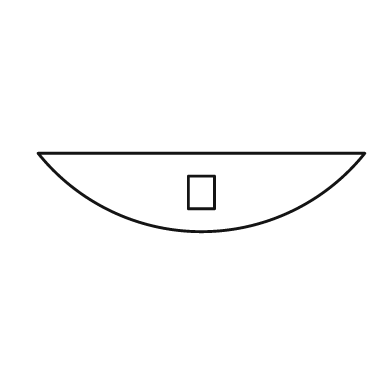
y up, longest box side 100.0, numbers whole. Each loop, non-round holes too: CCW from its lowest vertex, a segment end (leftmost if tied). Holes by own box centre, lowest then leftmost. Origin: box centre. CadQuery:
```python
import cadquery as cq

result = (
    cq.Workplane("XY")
    .moveTo(-50.0, 12.0)
    .threePointArc((0.0, -12.0), (50.0, 12.0))
    .close()
    .moveTo(-4.0, -5.0)
    .lineTo(4.0, -5.0)
    .lineTo(4.0, 5.0)
    .lineTo(-4.0, 5.0)
    .close()
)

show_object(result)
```